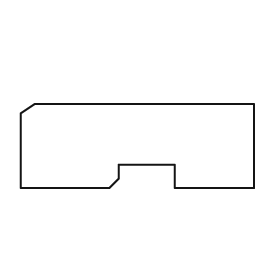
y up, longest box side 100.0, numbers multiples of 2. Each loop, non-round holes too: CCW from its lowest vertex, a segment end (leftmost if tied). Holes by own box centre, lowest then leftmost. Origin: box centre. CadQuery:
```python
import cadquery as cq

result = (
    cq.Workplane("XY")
    .moveTo(-50.0, -18.0)
    .lineTo(-12.0, -18.0)
    .lineTo(-8.0, -14.0)
    .lineTo(-8.0, -8.0)
    .lineTo(16.0, -8.0)
    .lineTo(16.0, -18.0)
    .lineTo(50.0, -18.0)
    .lineTo(50.0, 18.0)
    .lineTo(-44.0, 18.0)
    .lineTo(-50.0, 14.0)
    .close()
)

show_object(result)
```